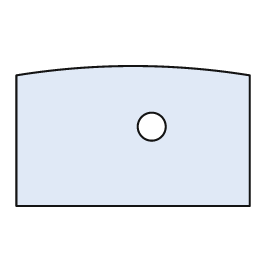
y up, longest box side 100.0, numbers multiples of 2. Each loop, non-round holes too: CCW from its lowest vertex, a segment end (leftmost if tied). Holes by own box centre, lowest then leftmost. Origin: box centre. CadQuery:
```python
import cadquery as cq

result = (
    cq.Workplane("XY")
    .moveTo(-50.0, -30.0)
    .lineTo(50.0, -30.0)
    .lineTo(50.0, 26.0)
    .threePointArc((0.0, 30.0), (-50.0, 26.0))
    .close()
    .moveTo(8.0, 4.0)
    .circle(6.0)
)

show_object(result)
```